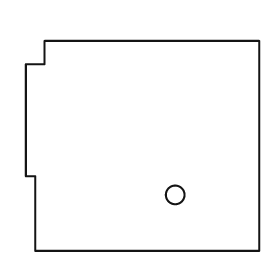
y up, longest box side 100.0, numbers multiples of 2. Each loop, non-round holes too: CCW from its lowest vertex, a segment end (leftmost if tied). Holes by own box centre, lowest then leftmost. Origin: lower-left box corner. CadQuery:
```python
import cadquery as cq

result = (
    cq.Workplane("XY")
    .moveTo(4.0, 0.0)
    .lineTo(100.0, 0.0)
    .lineTo(100.0, 90.0)
    .lineTo(8.0, 90.0)
    .lineTo(8.0, 80.0)
    .lineTo(0.0, 80.0)
    .lineTo(0.0, 32.0)
    .lineTo(4.0, 32.0)
    .close()
    .moveTo(64.0, 24.0)
    .circle(4.0)
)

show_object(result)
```